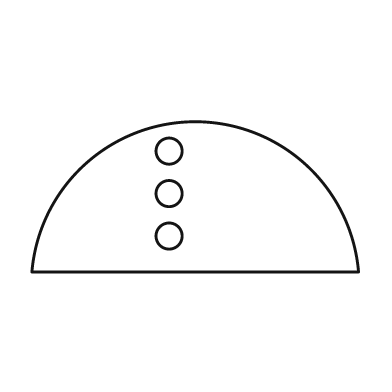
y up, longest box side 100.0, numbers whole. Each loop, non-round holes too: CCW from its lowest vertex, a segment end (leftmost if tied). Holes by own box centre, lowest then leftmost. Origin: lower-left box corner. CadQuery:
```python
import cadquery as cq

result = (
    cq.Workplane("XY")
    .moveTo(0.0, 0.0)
    .lineTo(100.0, 0.0)
    .threePointArc((50.0, 46.0), (0.0, 0.0))
    .close()
    .moveTo(42.0, 11.0)
    .circle(4.0)
    .moveTo(42.0, 24.0)
    .circle(4.0)
    .moveTo(42.0, 37.0)
    .circle(4.0)
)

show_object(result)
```